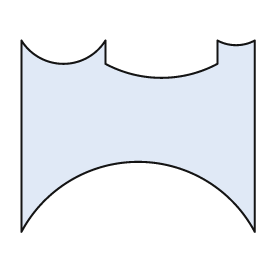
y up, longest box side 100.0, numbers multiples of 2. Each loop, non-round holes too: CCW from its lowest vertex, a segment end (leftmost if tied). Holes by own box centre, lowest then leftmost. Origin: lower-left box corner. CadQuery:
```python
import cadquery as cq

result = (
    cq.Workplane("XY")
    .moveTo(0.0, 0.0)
    .threePointArc((50.0, 30.0), (100.0, 0.0))
    .lineTo(100.0, 82.0)
    .threePointArc((92.0, 80.0), (84.0, 82.0))
    .lineTo(84.0, 72.0)
    .threePointArc((60.0, 66.0), (36.0, 72.0))
    .lineTo(36.0, 82.0)
    .threePointArc((18.0, 72.0), (0.0, 82.0))
    .close()
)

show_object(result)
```